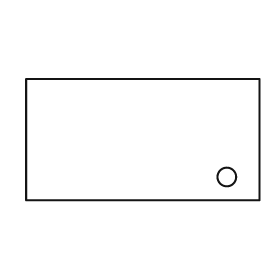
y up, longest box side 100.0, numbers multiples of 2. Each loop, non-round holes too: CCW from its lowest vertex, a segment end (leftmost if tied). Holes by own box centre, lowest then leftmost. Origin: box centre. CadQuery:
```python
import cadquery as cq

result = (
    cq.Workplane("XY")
    .moveTo(-50.0, -26.0)
    .lineTo(50.0, -26.0)
    .lineTo(50.0, 26.0)
    .lineTo(-50.0, 26.0)
    .close()
    .moveTo(36.0, -16.0)
    .circle(4.0)
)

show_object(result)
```